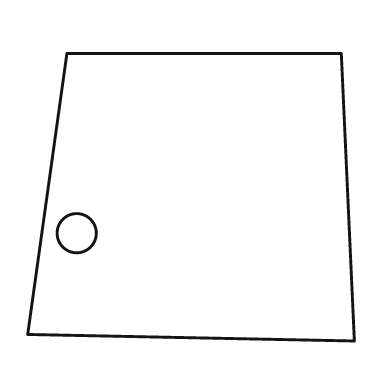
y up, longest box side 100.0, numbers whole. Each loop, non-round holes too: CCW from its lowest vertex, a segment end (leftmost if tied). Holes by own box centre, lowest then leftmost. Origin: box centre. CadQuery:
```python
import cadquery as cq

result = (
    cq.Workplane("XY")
    .moveTo(50.0, -44.0)
    .lineTo(46.0, 44.0)
    .lineTo(-38.0, 44.0)
    .lineTo(-50.0, -42.0)
    .close()
    .moveTo(-35.0, -11.0)
    .circle(6.0)
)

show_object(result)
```